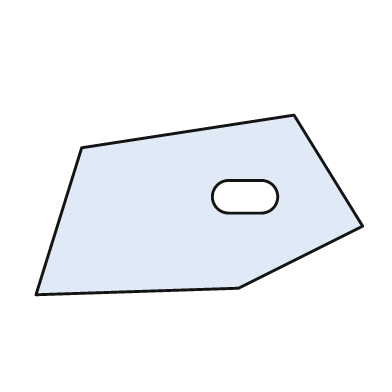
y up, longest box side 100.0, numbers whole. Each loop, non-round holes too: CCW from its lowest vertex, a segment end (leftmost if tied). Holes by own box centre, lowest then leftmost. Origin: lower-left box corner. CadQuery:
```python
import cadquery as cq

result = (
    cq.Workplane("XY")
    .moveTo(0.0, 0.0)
    .lineTo(62.0, 2.0)
    .lineTo(100.0, 21.0)
    .lineTo(79.0, 55.0)
    .lineTo(14.0, 45.0)
    .close()
    .moveTo(59.0, 25.0)
    .lineTo(69.0, 25.0)
    .threePointArc((74.0, 30.0), (69.0, 35.0))
    .lineTo(59.0, 35.0)
    .threePointArc((54.0, 30.0), (59.0, 25.0))
    .close()
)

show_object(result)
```